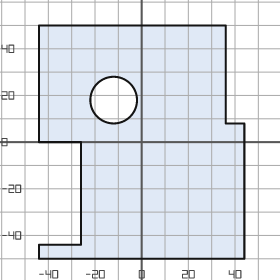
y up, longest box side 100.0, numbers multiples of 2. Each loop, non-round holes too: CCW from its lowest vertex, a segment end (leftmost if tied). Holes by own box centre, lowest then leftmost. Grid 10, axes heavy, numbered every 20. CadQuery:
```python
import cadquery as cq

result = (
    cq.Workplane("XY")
    .moveTo(-44.0, -50.0)
    .lineTo(44.0, -50.0)
    .lineTo(44.0, 8.0)
    .lineTo(36.0, 8.0)
    .lineTo(36.0, 50.0)
    .lineTo(-44.0, 50.0)
    .lineTo(-44.0, 0.0)
    .lineTo(-26.0, 0.0)
    .lineTo(-26.0, -44.0)
    .lineTo(-44.0, -44.0)
    .close()
    .moveTo(-12.0, 18.0)
    .circle(10.0)
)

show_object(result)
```